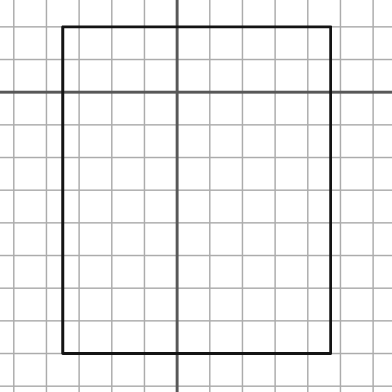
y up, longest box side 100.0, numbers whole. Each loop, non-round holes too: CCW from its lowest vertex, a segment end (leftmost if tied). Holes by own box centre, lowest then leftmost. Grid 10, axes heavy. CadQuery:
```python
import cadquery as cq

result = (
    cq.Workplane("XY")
    .moveTo(-35.0, -80.0)
    .lineTo(47.0, -80.0)
    .lineTo(47.0, 20.0)
    .lineTo(-35.0, 20.0)
    .close()
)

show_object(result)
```